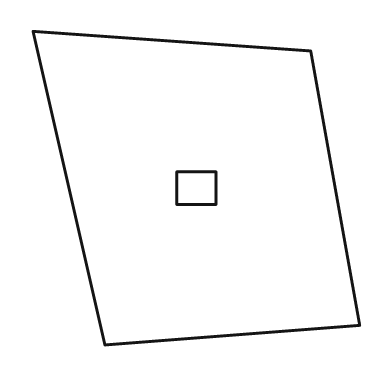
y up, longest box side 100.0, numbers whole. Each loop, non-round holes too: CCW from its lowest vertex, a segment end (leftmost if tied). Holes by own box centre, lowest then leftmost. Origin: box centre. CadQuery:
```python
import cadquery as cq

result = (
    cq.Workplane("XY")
    .moveTo(-28.0, -48.0)
    .lineTo(50.0, -42.0)
    .lineTo(35.0, 42.0)
    .lineTo(-50.0, 48.0)
    .close()
    .moveTo(-6.0, -5.0)
    .lineTo(6.0, -5.0)
    .lineTo(6.0, 5.0)
    .lineTo(-6.0, 5.0)
    .close()
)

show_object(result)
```